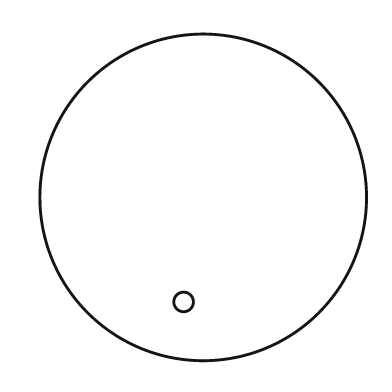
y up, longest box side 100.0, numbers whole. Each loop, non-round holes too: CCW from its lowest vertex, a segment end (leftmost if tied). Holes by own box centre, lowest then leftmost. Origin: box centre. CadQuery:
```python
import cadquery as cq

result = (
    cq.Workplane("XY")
    .moveTo(0.0, 0.0)
    .circle(50.0)
    .moveTo(-6.0, -32.0)
    .circle(3.0)
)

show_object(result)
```